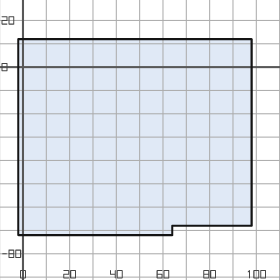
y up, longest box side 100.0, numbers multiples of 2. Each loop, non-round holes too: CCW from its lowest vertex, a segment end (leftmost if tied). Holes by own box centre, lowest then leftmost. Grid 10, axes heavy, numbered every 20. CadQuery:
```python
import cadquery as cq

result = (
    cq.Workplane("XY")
    .moveTo(-2.0, -72.0)
    .lineTo(64.0, -72.0)
    .lineTo(64.0, -68.0)
    .lineTo(98.0, -68.0)
    .lineTo(98.0, 12.0)
    .lineTo(-2.0, 12.0)
    .close()
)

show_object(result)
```